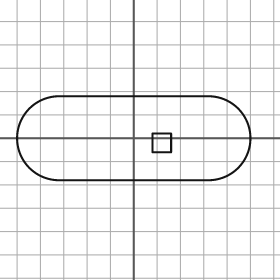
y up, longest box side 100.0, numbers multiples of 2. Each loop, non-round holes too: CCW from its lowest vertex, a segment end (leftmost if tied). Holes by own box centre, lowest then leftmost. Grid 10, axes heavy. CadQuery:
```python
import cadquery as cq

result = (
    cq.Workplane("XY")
    .moveTo(-32.0, -18.0)
    .lineTo(32.0, -18.0)
    .threePointArc((50.0, 0.0), (32.0, 18.0))
    .lineTo(-32.0, 18.0)
    .threePointArc((-50.0, 0.0), (-32.0, -18.0))
    .close()
    .moveTo(8.0, -6.0)
    .lineTo(16.0, -6.0)
    .lineTo(16.0, 2.0)
    .lineTo(8.0, 2.0)
    .close()
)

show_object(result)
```